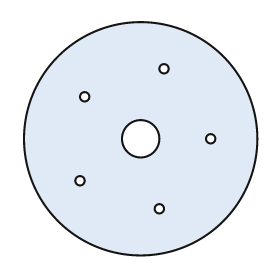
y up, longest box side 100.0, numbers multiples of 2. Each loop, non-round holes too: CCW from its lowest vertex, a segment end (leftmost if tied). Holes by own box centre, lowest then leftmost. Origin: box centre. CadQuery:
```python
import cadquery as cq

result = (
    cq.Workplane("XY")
    .moveTo(0.0, 0.0)
    .circle(50.0)
    .moveTo(8.0, -30.0)
    .circle(2.0)
    .moveTo(-26.0, -18.0)
    .circle(2.0)
    .moveTo(0.0, 0.0)
    .circle(8.0)
    .moveTo(30.0, 0.0)
    .circle(2.0)
    .moveTo(-24.0, 18.0)
    .circle(2.0)
    .moveTo(10.0, 30.0)
    .circle(2.0)
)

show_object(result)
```